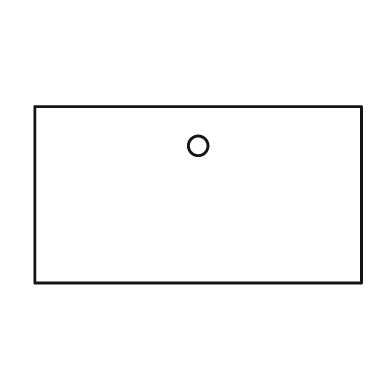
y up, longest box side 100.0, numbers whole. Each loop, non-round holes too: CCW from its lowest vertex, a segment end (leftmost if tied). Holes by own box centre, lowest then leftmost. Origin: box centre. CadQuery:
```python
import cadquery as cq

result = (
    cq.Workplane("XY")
    .moveTo(-50.0, -27.0)
    .lineTo(50.0, -27.0)
    .lineTo(50.0, 27.0)
    .lineTo(-50.0, 27.0)
    .close()
    .moveTo(0.0, 15.0)
    .circle(3.0)
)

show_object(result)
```